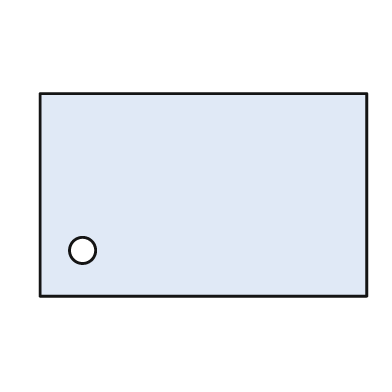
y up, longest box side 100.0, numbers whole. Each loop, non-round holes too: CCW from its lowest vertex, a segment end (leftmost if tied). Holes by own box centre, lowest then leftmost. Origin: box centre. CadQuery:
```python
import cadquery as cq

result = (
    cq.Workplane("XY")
    .moveTo(-50.0, -31.0)
    .lineTo(50.0, -31.0)
    .lineTo(50.0, 31.0)
    .lineTo(-50.0, 31.0)
    .close()
    .moveTo(-37.0, -17.0)
    .circle(4.0)
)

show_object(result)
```